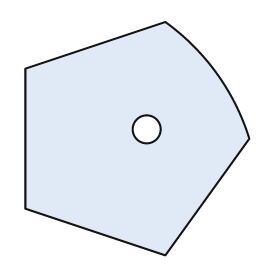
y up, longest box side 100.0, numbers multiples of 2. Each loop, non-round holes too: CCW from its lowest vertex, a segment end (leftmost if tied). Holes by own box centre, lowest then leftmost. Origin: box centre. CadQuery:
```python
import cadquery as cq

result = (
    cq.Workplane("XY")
    .moveTo(12.0, -50.0)
    .lineTo(48.0, 0.0)
    .threePointArc((34.0, 28.0), (12.0, 50.0))
    .lineTo(-48.0, 30.0)
    .lineTo(-48.0, -30.0)
    .close()
    .moveTo(4.0, 4.0)
    .circle(6.0)
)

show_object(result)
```